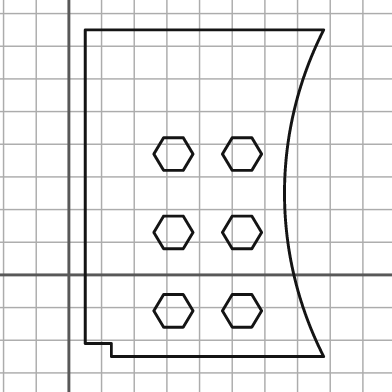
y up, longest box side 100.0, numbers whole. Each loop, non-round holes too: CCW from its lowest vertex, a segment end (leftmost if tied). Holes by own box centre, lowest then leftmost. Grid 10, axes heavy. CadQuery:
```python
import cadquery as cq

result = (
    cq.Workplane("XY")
    .moveTo(13.0, -25.0)
    .lineTo(78.0, -25.0)
    .threePointArc((66.0, 25.0), (78.0, 75.0))
    .lineTo(5.0, 75.0)
    .lineTo(5.0, -21.0)
    .lineTo(13.0, -21.0)
    .close()
    .moveTo(29.0, -16.0)
    .lineTo(35.0, -16.0)
    .lineTo(38.0, -11.0)
    .lineTo(35.0, -6.0)
    .lineTo(29.0, -6.0)
    .lineTo(26.0, -11.0)
    .close()
    .moveTo(50.0, -16.0)
    .lineTo(56.0, -16.0)
    .lineTo(59.0, -11.0)
    .lineTo(56.0, -6.0)
    .lineTo(50.0, -6.0)
    .lineTo(47.0, -11.0)
    .close()
    .moveTo(29.0, 8.0)
    .lineTo(35.0, 8.0)
    .lineTo(38.0, 13.0)
    .lineTo(35.0, 18.0)
    .lineTo(29.0, 18.0)
    .lineTo(26.0, 13.0)
    .close()
    .moveTo(50.0, 8.0)
    .lineTo(56.0, 8.0)
    .lineTo(59.0, 13.0)
    .lineTo(56.0, 18.0)
    .lineTo(50.0, 18.0)
    .lineTo(47.0, 13.0)
    .close()
    .moveTo(29.0, 32.0)
    .lineTo(35.0, 32.0)
    .lineTo(38.0, 37.0)
    .lineTo(35.0, 42.0)
    .lineTo(29.0, 42.0)
    .lineTo(26.0, 37.0)
    .close()
    .moveTo(50.0, 32.0)
    .lineTo(56.0, 32.0)
    .lineTo(59.0, 37.0)
    .lineTo(56.0, 42.0)
    .lineTo(50.0, 42.0)
    .lineTo(47.0, 37.0)
    .close()
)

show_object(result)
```